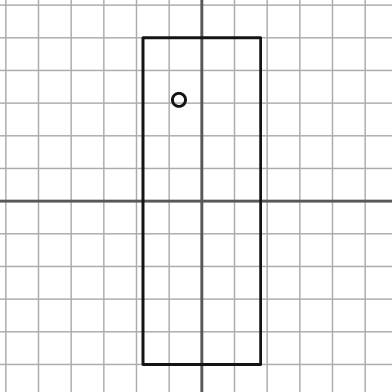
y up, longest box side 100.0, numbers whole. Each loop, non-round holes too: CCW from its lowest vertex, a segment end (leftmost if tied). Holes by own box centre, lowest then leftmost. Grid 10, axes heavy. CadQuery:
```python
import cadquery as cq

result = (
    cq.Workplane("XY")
    .moveTo(-18.0, -50.0)
    .lineTo(18.0, -50.0)
    .lineTo(18.0, 50.0)
    .lineTo(-18.0, 50.0)
    .close()
    .moveTo(-7.0, 31.0)
    .circle(2.0)
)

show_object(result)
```